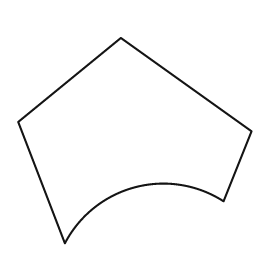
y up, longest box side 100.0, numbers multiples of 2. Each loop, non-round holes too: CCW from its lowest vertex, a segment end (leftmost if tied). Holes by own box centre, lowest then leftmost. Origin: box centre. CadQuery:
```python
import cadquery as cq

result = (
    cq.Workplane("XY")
    .moveTo(-30.0, -44.0)
    .threePointArc((0.0, -20.0), (38.0, -26.0))
    .lineTo(50.0, 4.0)
    .lineTo(-6.0, 44.0)
    .lineTo(-50.0, 8.0)
    .close()
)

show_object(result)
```